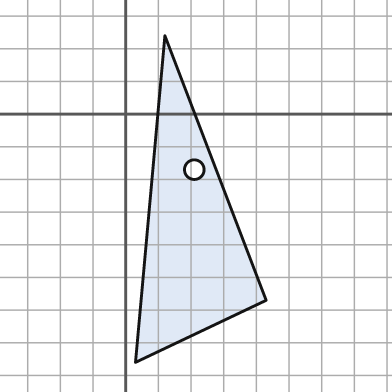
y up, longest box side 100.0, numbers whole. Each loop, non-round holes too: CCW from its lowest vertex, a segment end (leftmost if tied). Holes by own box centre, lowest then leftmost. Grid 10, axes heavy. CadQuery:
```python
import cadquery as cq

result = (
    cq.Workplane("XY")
    .moveTo(3.0, -76.0)
    .lineTo(43.0, -57.0)
    .lineTo(12.0, 24.0)
    .close()
    .moveTo(21.0, -17.0)
    .circle(3.0)
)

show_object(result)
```